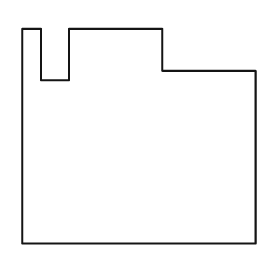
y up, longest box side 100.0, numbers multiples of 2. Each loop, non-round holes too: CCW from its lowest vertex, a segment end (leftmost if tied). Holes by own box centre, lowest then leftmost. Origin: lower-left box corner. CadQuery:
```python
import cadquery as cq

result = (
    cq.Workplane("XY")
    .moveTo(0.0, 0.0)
    .lineTo(100.0, 0.0)
    .lineTo(100.0, 74.0)
    .lineTo(60.0, 74.0)
    .lineTo(60.0, 92.0)
    .lineTo(20.0, 92.0)
    .lineTo(20.0, 70.0)
    .lineTo(8.0, 70.0)
    .lineTo(8.0, 92.0)
    .lineTo(0.0, 92.0)
    .close()
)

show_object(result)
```